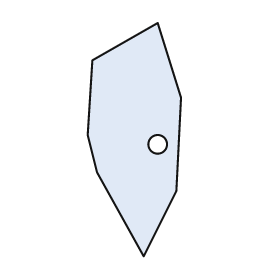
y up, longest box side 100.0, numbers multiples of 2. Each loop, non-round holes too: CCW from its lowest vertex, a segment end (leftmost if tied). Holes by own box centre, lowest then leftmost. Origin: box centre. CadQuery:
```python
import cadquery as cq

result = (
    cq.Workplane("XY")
    .moveTo(4.0, -50.0)
    .lineTo(18.0, -22.0)
    .lineTo(20.0, 18.0)
    .lineTo(10.0, 50.0)
    .lineTo(-18.0, 34.0)
    .lineTo(-20.0, 2.0)
    .lineTo(-16.0, -14.0)
    .close()
    .moveTo(10.0, -2.0)
    .circle(4.0)
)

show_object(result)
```